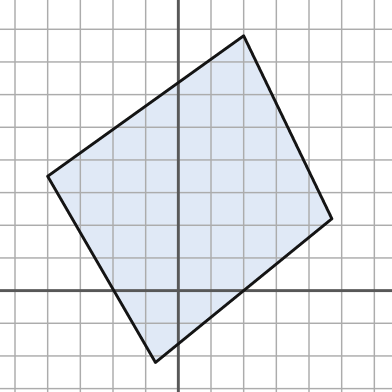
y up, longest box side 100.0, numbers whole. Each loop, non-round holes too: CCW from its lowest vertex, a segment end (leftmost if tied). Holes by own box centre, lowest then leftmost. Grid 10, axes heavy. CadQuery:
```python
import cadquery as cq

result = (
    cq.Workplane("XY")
    .moveTo(-7.0, -22.0)
    .lineTo(47.0, 22.0)
    .lineTo(20.0, 78.0)
    .lineTo(-40.0, 35.0)
    .close()
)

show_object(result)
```